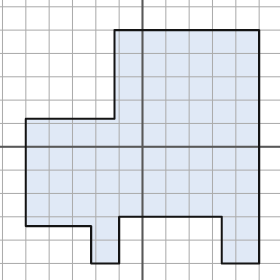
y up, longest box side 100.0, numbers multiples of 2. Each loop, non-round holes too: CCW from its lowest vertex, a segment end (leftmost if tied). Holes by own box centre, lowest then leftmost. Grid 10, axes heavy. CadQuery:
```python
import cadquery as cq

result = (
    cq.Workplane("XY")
    .moveTo(-22.0, -50.0)
    .lineTo(-10.0, -50.0)
    .lineTo(-10.0, -30.0)
    .lineTo(34.0, -30.0)
    .lineTo(34.0, -50.0)
    .lineTo(50.0, -50.0)
    .lineTo(50.0, 50.0)
    .lineTo(-12.0, 50.0)
    .lineTo(-12.0, 12.0)
    .lineTo(-50.0, 12.0)
    .lineTo(-50.0, -34.0)
    .lineTo(-22.0, -34.0)
    .close()
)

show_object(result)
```